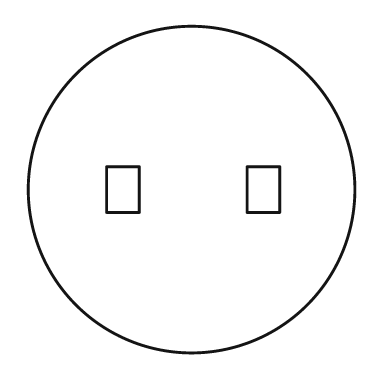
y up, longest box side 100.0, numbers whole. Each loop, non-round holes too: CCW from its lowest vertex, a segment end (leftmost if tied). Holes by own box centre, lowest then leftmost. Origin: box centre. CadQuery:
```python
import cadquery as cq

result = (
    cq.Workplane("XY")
    .moveTo(0.0, 0.0)
    .circle(50.0)
    .moveTo(-26.0, -7.0)
    .lineTo(-16.0, -7.0)
    .lineTo(-16.0, 7.0)
    .lineTo(-26.0, 7.0)
    .close()
    .moveTo(17.0, -7.0)
    .lineTo(27.0, -7.0)
    .lineTo(27.0, 7.0)
    .lineTo(17.0, 7.0)
    .close()
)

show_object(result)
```